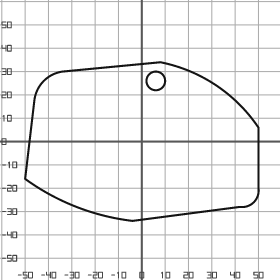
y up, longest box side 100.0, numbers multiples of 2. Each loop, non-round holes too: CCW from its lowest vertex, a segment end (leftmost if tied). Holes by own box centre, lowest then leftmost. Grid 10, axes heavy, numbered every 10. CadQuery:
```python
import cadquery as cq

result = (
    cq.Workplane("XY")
    .moveTo(-4.0, -34.0)
    .lineTo(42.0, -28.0)
    .threePointArc((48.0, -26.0), (50.0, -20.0))
    .lineTo(50.0, 6.0)
    .threePointArc((32.0, 24.0), (8.0, 34.0))
    .lineTo(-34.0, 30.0)
    .threePointArc((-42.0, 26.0), (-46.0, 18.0))
    .lineTo(-50.0, -16.0)
    .threePointArc((-28.0, -28.0), (-4.0, -34.0))
    .close()
    .moveTo(6.0, 26.0)
    .circle(4.0)
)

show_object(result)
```